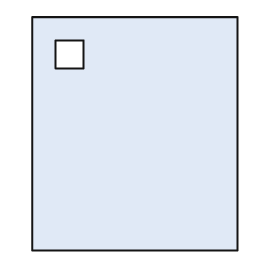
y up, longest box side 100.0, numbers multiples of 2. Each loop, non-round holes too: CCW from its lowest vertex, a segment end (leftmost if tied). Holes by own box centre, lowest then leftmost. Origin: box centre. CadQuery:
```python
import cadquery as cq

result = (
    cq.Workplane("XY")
    .moveTo(-44.0, -50.0)
    .lineTo(44.0, -50.0)
    .lineTo(44.0, 50.0)
    .lineTo(-44.0, 50.0)
    .close()
    .moveTo(-34.0, 28.0)
    .lineTo(-22.0, 28.0)
    .lineTo(-22.0, 40.0)
    .lineTo(-34.0, 40.0)
    .close()
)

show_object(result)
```